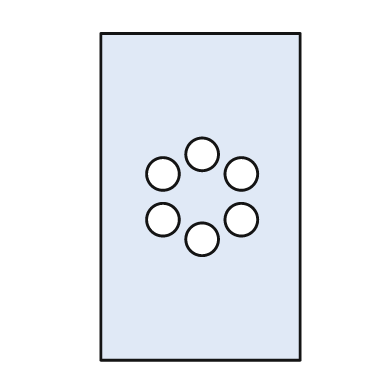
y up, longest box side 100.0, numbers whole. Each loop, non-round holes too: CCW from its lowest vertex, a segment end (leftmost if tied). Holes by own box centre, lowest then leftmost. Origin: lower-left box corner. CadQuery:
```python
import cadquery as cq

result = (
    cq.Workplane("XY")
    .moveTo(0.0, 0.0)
    .lineTo(61.0, 0.0)
    .lineTo(61.0, 100.0)
    .lineTo(0.0, 100.0)
    .close()
    .moveTo(31.0, 37.0)
    .circle(5.0)
    .moveTo(19.0, 43.0)
    .circle(5.0)
    .moveTo(43.0, 43.0)
    .circle(5.0)
    .moveTo(19.0, 57.0)
    .circle(5.0)
    .moveTo(43.0, 57.0)
    .circle(5.0)
    .moveTo(31.0, 63.0)
    .circle(5.0)
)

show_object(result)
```